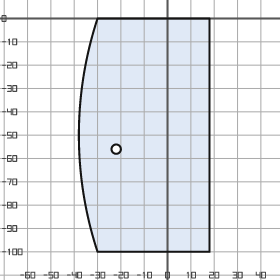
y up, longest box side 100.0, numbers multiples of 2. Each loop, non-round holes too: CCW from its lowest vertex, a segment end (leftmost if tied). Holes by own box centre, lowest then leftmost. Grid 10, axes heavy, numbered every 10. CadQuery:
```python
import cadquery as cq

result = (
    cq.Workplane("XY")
    .moveTo(-30.0, -100.0)
    .lineTo(18.0, -100.0)
    .lineTo(18.0, 0.0)
    .lineTo(-30.0, 0.0)
    .threePointArc((-38.0, -50.0), (-30.0, -100.0))
    .close()
    .moveTo(-22.0, -56.0)
    .circle(2.0)
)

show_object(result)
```